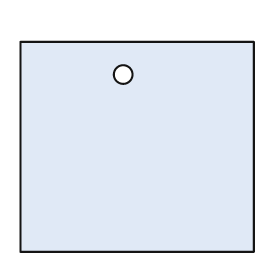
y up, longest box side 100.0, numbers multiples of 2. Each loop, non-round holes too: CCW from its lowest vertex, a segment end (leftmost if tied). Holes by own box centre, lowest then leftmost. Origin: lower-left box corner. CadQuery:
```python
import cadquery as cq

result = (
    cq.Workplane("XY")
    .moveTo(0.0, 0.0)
    .lineTo(100.0, 0.0)
    .lineTo(100.0, 90.0)
    .lineTo(0.0, 90.0)
    .close()
    .moveTo(44.0, 76.0)
    .circle(4.0)
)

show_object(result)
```